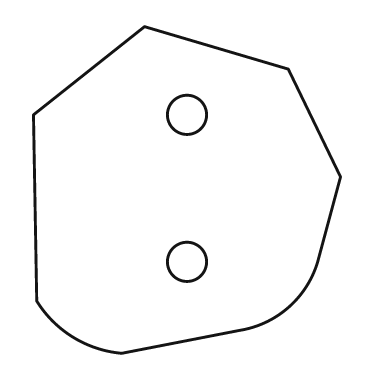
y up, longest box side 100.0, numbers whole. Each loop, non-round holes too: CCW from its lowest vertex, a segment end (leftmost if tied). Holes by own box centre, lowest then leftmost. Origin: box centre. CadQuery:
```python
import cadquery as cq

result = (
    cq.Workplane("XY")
    .moveTo(-20.0, -50.0)
    .lineTo(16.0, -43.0)
    .threePointArc((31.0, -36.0), (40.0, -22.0))
    .lineTo(47.0, 4.0)
    .lineTo(31.0, 37.0)
    .lineTo(-13.0, 50.0)
    .lineTo(-47.0, 23.0)
    .lineTo(-46.0, -34.0)
    .threePointArc((-35.0, -45.0), (-20.0, -50.0))
    .close()
    .moveTo(0.0, -22.0)
    .circle(6.0)
    .moveTo(0.0, 23.0)
    .circle(6.0)
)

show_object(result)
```